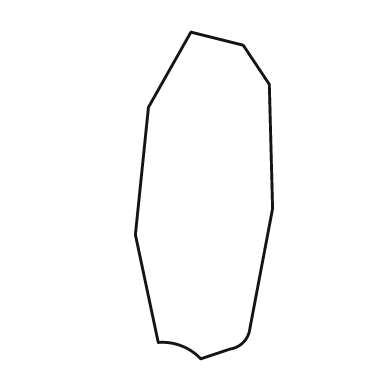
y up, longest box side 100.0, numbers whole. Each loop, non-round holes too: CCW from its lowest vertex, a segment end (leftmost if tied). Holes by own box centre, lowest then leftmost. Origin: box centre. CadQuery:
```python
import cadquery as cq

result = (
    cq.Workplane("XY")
    .moveTo(-1.0, -50.0)
    .lineTo(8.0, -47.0)
    .threePointArc((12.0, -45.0), (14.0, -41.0))
    .lineTo(21.0, -4.0)
    .lineTo(20.0, 34.0)
    .lineTo(12.0, 46.0)
    .lineTo(-4.0, 50.0)
    .lineTo(-17.0, 27.0)
    .lineTo(-21.0, -12.0)
    .lineTo(-14.0, -45.0)
    .threePointArc((-7.0, -46.0), (-1.0, -50.0))
    .close()
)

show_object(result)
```